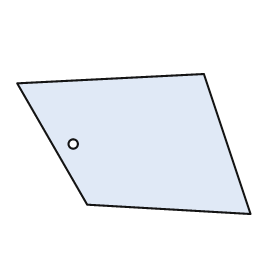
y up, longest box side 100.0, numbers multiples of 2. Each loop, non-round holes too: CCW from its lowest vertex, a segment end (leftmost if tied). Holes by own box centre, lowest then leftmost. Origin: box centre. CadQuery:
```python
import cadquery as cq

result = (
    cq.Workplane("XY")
    .moveTo(50.0, -30.0)
    .lineTo(30.0, 30.0)
    .lineTo(-50.0, 26.0)
    .lineTo(-20.0, -26.0)
    .close()
    .moveTo(-26.0, 0.0)
    .circle(2.0)
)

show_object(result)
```